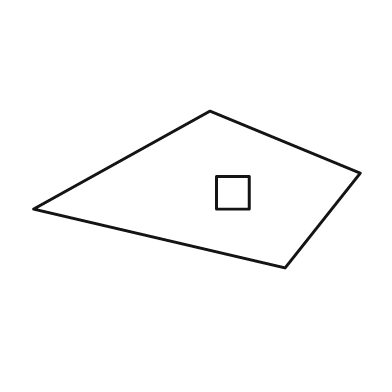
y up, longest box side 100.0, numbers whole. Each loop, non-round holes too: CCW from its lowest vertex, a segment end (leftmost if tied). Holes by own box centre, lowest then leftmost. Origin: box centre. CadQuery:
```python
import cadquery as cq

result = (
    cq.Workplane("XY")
    .moveTo(27.0, -24.0)
    .lineTo(50.0, 5.0)
    .lineTo(4.0, 24.0)
    .lineTo(-50.0, -6.0)
    .close()
    .moveTo(6.0, -6.0)
    .lineTo(16.0, -6.0)
    .lineTo(16.0, 4.0)
    .lineTo(6.0, 4.0)
    .close()
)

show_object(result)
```